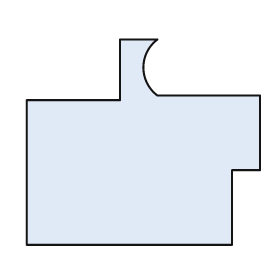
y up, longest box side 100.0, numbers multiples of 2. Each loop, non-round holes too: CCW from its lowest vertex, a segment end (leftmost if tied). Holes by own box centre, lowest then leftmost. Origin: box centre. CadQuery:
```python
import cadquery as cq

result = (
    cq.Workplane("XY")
    .moveTo(-50.0, -44.0)
    .lineTo(38.0, -44.0)
    .lineTo(38.0, -12.0)
    .lineTo(50.0, -12.0)
    .lineTo(50.0, 20.0)
    .lineTo(6.0, 20.0)
    .threePointArc((0.0, 32.0), (6.0, 44.0))
    .lineTo(-10.0, 44.0)
    .lineTo(-10.0, 18.0)
    .lineTo(-50.0, 18.0)
    .close()
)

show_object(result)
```